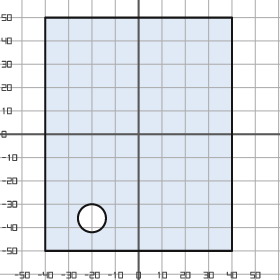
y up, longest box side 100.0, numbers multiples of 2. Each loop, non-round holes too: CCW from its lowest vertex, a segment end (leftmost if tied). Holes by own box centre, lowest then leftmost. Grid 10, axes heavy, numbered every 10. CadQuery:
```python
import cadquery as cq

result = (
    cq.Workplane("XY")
    .moveTo(-40.0, -50.0)
    .lineTo(40.0, -50.0)
    .lineTo(40.0, 50.0)
    .lineTo(-40.0, 50.0)
    .close()
    .moveTo(-20.0, -36.0)
    .circle(6.0)
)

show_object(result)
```